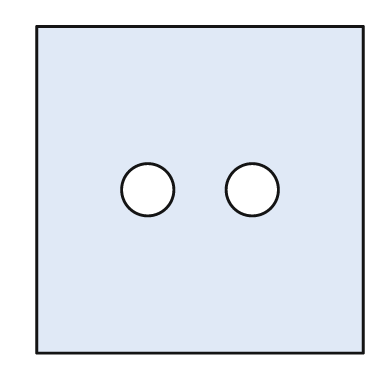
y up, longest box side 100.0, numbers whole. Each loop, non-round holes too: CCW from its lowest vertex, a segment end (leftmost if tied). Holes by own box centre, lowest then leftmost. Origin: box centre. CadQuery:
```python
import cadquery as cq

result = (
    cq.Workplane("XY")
    .moveTo(-50.0, -50.0)
    .lineTo(50.0, -50.0)
    .lineTo(50.0, 50.0)
    .lineTo(-50.0, 50.0)
    .close()
    .moveTo(-16.0, 0.0)
    .circle(8.0)
    .moveTo(16.0, 0.0)
    .circle(8.0)
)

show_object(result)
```